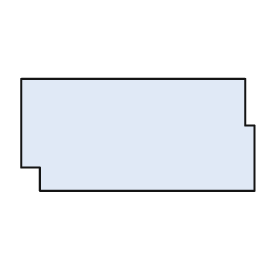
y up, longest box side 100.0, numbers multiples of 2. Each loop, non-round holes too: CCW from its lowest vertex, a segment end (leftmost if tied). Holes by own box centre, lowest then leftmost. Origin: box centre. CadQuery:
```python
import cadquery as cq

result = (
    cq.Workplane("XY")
    .moveTo(-42.0, -24.0)
    .lineTo(50.0, -24.0)
    .lineTo(50.0, 4.0)
    .lineTo(46.0, 4.0)
    .lineTo(46.0, 24.0)
    .lineTo(-50.0, 24.0)
    .lineTo(-50.0, -14.0)
    .lineTo(-42.0, -14.0)
    .close()
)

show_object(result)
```